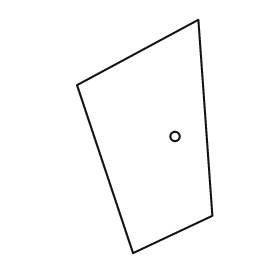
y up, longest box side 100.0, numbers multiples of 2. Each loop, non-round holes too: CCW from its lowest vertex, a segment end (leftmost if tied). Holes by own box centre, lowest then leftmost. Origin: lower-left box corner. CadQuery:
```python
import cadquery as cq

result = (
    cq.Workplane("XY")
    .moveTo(24.0, 0.0)
    .lineTo(58.0, 16.0)
    .lineTo(52.0, 100.0)
    .lineTo(0.0, 72.0)
    .close()
    .moveTo(42.0, 50.0)
    .circle(2.0)
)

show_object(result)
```